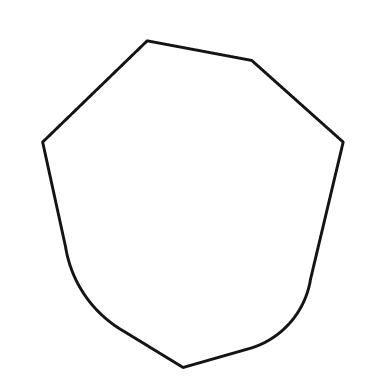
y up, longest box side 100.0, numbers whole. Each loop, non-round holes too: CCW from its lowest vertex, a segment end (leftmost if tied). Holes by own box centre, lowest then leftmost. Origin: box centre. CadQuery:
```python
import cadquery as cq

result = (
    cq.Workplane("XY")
    .moveTo(-3.0, -50.0)
    .lineTo(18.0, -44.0)
    .threePointArc((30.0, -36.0), (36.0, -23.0))
    .lineTo(46.0, 19.0)
    .lineTo(18.0, 44.0)
    .lineTo(-14.0, 50.0)
    .lineTo(-46.0, 19.0)
    .lineTo(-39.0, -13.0)
    .threePointArc((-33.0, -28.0), (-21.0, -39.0))
    .close()
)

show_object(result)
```